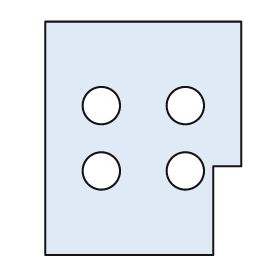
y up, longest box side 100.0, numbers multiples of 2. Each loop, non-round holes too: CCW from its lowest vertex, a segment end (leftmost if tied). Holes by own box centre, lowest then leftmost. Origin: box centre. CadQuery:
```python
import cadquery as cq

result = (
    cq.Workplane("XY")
    .moveTo(-42.0, -50.0)
    .lineTo(30.0, -50.0)
    .lineTo(30.0, -12.0)
    .lineTo(42.0, -12.0)
    .lineTo(42.0, 50.0)
    .lineTo(-42.0, 50.0)
    .close()
    .moveTo(-18.0, -14.0)
    .circle(8.0)
    .moveTo(18.0, -14.0)
    .circle(8.0)
    .moveTo(-18.0, 14.0)
    .circle(8.0)
    .moveTo(18.0, 14.0)
    .circle(8.0)
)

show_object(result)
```